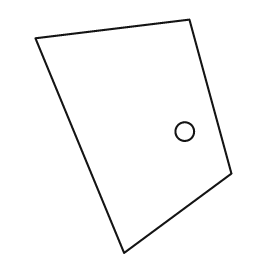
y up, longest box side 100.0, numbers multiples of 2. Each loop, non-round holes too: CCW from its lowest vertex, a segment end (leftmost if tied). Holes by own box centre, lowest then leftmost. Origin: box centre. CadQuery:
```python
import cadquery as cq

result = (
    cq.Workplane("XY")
    .moveTo(-4.0, -50.0)
    .lineTo(42.0, -16.0)
    .lineTo(24.0, 50.0)
    .lineTo(-42.0, 42.0)
    .close()
    .moveTo(22.0, 2.0)
    .circle(4.0)
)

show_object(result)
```